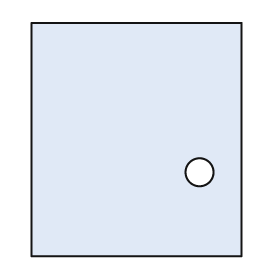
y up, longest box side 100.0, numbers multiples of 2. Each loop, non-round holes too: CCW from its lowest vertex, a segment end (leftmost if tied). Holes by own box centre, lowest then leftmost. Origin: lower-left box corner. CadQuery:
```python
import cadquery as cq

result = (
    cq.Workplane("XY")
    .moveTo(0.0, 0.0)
    .lineTo(90.0, 0.0)
    .lineTo(90.0, 100.0)
    .lineTo(0.0, 100.0)
    .close()
    .moveTo(72.0, 36.0)
    .circle(6.0)
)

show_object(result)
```